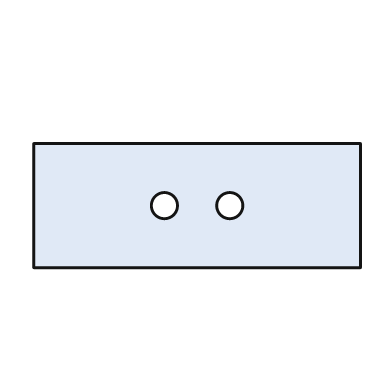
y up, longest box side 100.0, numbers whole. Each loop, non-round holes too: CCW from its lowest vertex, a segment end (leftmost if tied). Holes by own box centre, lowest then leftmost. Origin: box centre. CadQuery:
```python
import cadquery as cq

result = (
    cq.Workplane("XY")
    .moveTo(-50.0, -19.0)
    .lineTo(50.0, -19.0)
    .lineTo(50.0, 19.0)
    .lineTo(-50.0, 19.0)
    .close()
    .moveTo(-10.0, 0.0)
    .circle(4.0)
    .moveTo(10.0, 0.0)
    .circle(4.0)
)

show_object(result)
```